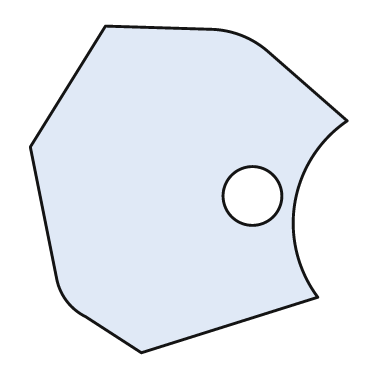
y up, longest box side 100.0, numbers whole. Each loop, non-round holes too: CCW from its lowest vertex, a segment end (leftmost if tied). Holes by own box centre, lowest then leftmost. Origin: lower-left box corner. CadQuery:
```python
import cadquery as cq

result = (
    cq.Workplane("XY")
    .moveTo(34.0, 0.0)
    .lineTo(88.0, 17.0)
    .threePointArc((81.0, 46.0), (97.0, 71.0))
    .lineTo(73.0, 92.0)
    .threePointArc((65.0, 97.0), (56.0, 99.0))
    .lineTo(23.0, 100.0)
    .lineTo(0.0, 63.0)
    .lineTo(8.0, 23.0)
    .threePointArc((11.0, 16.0), (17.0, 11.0))
    .close()
    .moveTo(68.0, 48.0)
    .circle(9.0)
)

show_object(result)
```